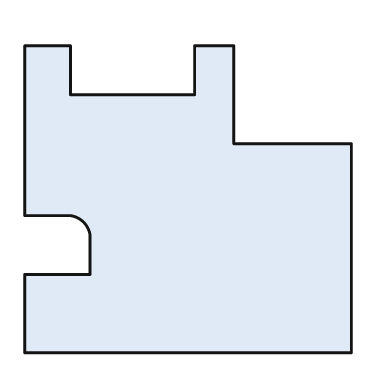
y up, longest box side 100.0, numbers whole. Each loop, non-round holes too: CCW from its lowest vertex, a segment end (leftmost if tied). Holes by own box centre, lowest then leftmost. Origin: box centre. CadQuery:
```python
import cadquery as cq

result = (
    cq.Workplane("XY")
    .moveTo(-50.0, -47.0)
    .lineTo(50.0, -47.0)
    .lineTo(50.0, 17.0)
    .lineTo(14.0, 17.0)
    .lineTo(14.0, 47.0)
    .lineTo(2.0, 47.0)
    .lineTo(2.0, 32.0)
    .lineTo(-36.0, 32.0)
    .lineTo(-36.0, 47.0)
    .lineTo(-50.0, 47.0)
    .lineTo(-50.0, -5.0)
    .lineTo(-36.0, -5.0)
    .threePointArc((-32.0, -7.0), (-30.0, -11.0))
    .lineTo(-30.0, -23.0)
    .lineTo(-50.0, -23.0)
    .close()
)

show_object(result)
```